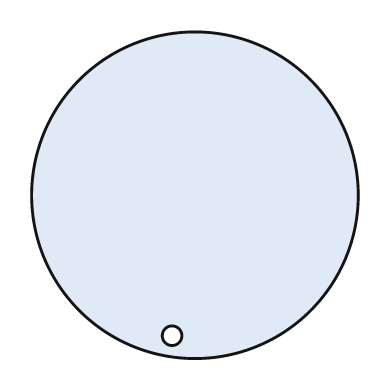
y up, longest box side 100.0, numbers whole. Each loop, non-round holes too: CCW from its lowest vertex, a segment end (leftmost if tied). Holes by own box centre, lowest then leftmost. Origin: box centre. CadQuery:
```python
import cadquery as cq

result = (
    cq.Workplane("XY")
    .moveTo(0.0, 0.0)
    .circle(50.0)
    .moveTo(-7.0, -43.0)
    .circle(3.0)
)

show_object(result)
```